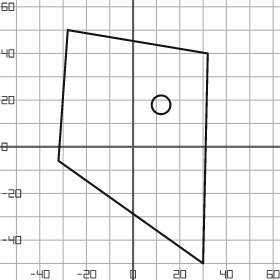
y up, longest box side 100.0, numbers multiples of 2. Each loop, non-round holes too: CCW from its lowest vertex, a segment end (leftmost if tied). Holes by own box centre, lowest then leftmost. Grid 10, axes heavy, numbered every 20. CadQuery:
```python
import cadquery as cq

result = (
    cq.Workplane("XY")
    .moveTo(30.0, -50.0)
    .lineTo(32.0, 40.0)
    .lineTo(-28.0, 50.0)
    .lineTo(-32.0, -6.0)
    .close()
    .moveTo(12.0, 18.0)
    .circle(4.0)
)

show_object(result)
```